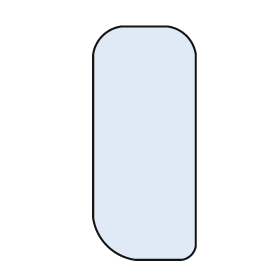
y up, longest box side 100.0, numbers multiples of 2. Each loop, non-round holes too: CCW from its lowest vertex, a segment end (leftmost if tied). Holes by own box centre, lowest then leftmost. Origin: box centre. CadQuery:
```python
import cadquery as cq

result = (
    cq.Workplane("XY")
    .moveTo(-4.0, -50.0)
    .lineTo(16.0, -50.0)
    .threePointArc((20.0, -48.0), (22.0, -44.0))
    .lineTo(22.0, 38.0)
    .threePointArc((18.0, 46.0), (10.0, 50.0))
    .lineTo(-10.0, 50.0)
    .threePointArc((-18.0, 46.0), (-22.0, 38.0))
    .lineTo(-22.0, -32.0)
    .threePointArc((-16.0, -44.0), (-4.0, -50.0))
    .close()
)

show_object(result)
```